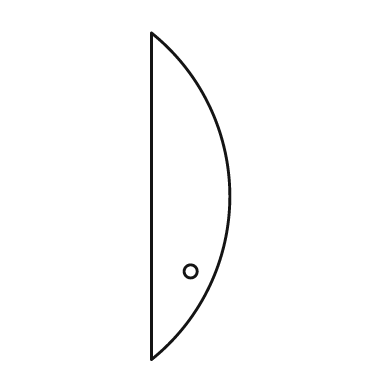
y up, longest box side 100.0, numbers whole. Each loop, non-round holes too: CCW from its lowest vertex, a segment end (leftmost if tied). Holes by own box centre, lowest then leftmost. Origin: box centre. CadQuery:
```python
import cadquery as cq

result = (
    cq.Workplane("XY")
    .moveTo(-12.0, -50.0)
    .threePointArc((12.0, 0.0), (-12.0, 50.0))
    .close()
    .moveTo(0.0, -23.0)
    .circle(2.0)
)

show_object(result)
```